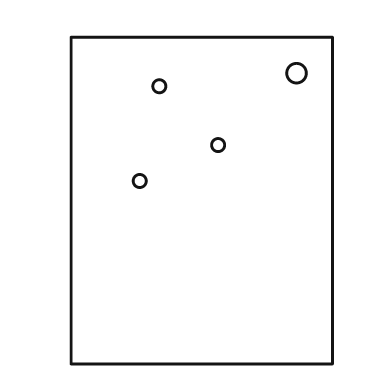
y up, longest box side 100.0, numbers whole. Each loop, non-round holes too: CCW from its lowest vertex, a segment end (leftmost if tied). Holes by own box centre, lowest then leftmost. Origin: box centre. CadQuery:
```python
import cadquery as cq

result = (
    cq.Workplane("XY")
    .moveTo(-40.0, -50.0)
    .lineTo(40.0, -50.0)
    .lineTo(40.0, 50.0)
    .lineTo(-40.0, 50.0)
    .close()
    .moveTo(-19.0, 6.0)
    .circle(2.0)
    .moveTo(5.0, 17.0)
    .circle(2.0)
    .moveTo(-13.0, 35.0)
    .circle(2.0)
    .moveTo(29.0, 39.0)
    .circle(3.0)
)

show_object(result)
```